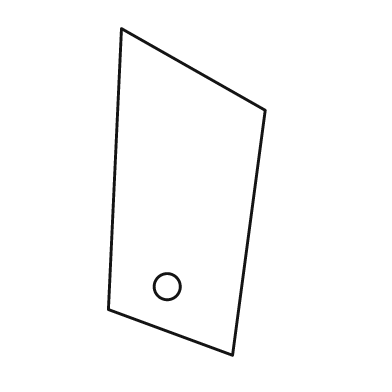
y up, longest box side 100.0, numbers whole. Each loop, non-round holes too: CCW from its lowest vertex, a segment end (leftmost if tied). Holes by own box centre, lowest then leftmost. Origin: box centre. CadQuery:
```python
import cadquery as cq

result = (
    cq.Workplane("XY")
    .moveTo(14.0, -50.0)
    .lineTo(24.0, 25.0)
    .lineTo(-20.0, 50.0)
    .lineTo(-24.0, -36.0)
    .close()
    .moveTo(-6.0, -29.0)
    .circle(4.0)
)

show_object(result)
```